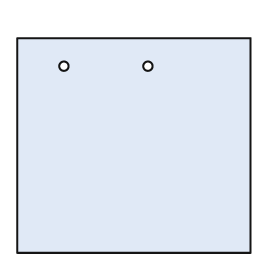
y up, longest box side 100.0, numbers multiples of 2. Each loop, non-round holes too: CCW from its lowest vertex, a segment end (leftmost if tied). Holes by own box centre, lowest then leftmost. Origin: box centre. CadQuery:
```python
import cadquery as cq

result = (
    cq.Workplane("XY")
    .moveTo(-50.0, -46.0)
    .lineTo(50.0, -46.0)
    .lineTo(50.0, 46.0)
    .lineTo(-50.0, 46.0)
    .close()
    .moveTo(-30.0, 34.0)
    .circle(2.0)
    .moveTo(6.0, 34.0)
    .circle(2.0)
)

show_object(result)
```